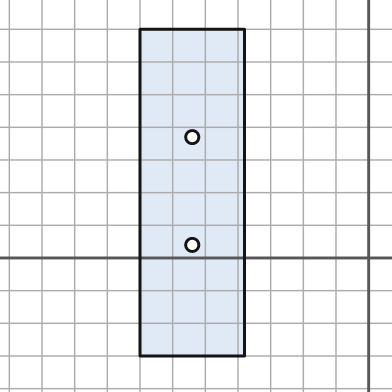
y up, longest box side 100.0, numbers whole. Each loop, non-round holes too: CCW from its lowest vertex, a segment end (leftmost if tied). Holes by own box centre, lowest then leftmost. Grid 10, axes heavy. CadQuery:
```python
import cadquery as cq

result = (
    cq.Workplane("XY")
    .moveTo(-70.0, -30.0)
    .lineTo(-38.0, -30.0)
    .lineTo(-38.0, 70.0)
    .lineTo(-70.0, 70.0)
    .close()
    .moveTo(-54.0, 4.0)
    .circle(2.0)
    .moveTo(-54.0, 37.0)
    .circle(2.0)
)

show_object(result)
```